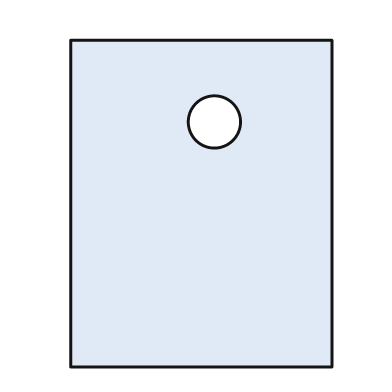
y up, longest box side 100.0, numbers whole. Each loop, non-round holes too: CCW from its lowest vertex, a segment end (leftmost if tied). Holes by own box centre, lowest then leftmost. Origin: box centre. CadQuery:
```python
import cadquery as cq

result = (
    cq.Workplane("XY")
    .moveTo(-40.0, -50.0)
    .lineTo(40.0, -50.0)
    .lineTo(40.0, 50.0)
    .lineTo(-40.0, 50.0)
    .close()
    .moveTo(4.0, 25.0)
    .circle(8.0)
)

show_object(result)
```